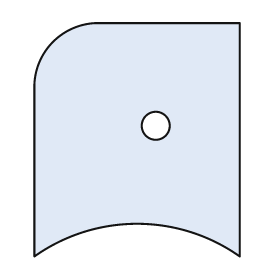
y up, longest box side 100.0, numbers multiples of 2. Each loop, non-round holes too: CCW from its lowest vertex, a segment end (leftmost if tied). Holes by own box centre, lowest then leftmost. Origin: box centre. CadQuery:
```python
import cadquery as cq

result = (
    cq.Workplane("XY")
    .moveTo(-44.0, -50.0)
    .threePointArc((0.0, -36.0), (44.0, -50.0))
    .lineTo(44.0, 50.0)
    .lineTo(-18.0, 50.0)
    .threePointArc((-36.0, 42.0), (-44.0, 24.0))
    .close()
    .moveTo(8.0, 6.0)
    .circle(6.0)
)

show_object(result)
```